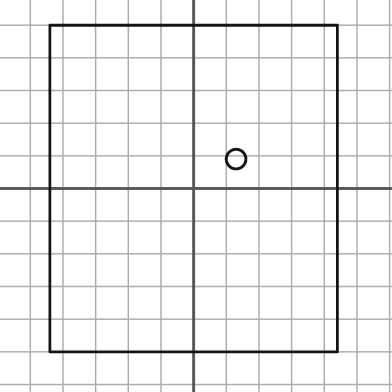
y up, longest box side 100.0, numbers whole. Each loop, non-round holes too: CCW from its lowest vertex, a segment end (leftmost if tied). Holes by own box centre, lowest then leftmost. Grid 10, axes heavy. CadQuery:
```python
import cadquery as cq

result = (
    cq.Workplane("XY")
    .moveTo(-44.0, -50.0)
    .lineTo(44.0, -50.0)
    .lineTo(44.0, 50.0)
    .lineTo(-44.0, 50.0)
    .close()
    .moveTo(13.0, 9.0)
    .circle(3.0)
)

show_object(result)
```